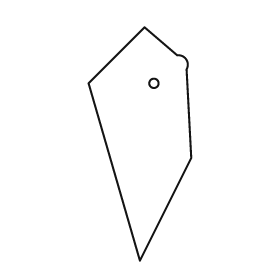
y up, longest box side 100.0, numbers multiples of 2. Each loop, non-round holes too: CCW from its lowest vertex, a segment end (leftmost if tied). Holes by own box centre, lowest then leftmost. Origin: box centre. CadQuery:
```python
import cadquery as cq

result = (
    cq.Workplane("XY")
    .moveTo(0.0, -50.0)
    .lineTo(22.0, -6.0)
    .lineTo(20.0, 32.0)
    .threePointArc((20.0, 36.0), (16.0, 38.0))
    .lineTo(2.0, 50.0)
    .lineTo(-22.0, 26.0)
    .close()
    .moveTo(6.0, 26.0)
    .circle(2.0)
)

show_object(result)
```